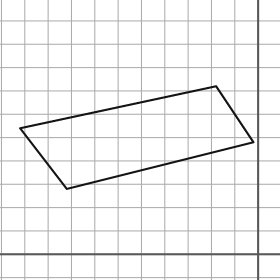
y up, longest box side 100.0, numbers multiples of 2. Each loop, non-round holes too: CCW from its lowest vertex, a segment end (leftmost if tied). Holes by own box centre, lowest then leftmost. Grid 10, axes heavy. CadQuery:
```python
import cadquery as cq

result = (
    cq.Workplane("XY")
    .moveTo(-82.0, 28.0)
    .lineTo(-2.0, 48.0)
    .lineTo(-18.0, 72.0)
    .lineTo(-102.0, 54.0)
    .close()
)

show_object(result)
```